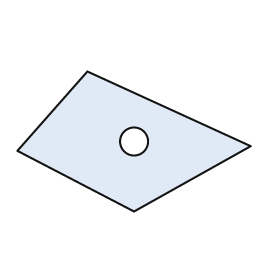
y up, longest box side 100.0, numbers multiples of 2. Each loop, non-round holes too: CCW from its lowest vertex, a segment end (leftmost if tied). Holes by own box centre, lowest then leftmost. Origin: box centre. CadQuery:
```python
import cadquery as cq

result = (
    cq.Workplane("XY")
    .moveTo(0.0, -30.0)
    .lineTo(50.0, -2.0)
    .lineTo(-20.0, 30.0)
    .lineTo(-50.0, -4.0)
    .close()
    .moveTo(0.0, 0.0)
    .circle(6.0)
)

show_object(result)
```